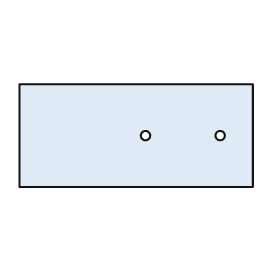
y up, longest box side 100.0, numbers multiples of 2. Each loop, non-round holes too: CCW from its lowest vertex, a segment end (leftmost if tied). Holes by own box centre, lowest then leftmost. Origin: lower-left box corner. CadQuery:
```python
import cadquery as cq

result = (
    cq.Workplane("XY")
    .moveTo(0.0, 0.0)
    .lineTo(100.0, 0.0)
    .lineTo(100.0, 44.0)
    .lineTo(0.0, 44.0)
    .close()
    .moveTo(54.0, 22.0)
    .circle(2.0)
    .moveTo(86.0, 22.0)
    .circle(2.0)
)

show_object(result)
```